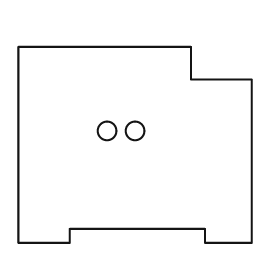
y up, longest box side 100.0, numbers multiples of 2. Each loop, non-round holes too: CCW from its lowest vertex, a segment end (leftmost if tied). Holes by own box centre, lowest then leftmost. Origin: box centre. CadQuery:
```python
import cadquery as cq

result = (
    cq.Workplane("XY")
    .moveTo(-50.0, -42.0)
    .lineTo(-28.0, -42.0)
    .lineTo(-28.0, -36.0)
    .lineTo(30.0, -36.0)
    .lineTo(30.0, -42.0)
    .lineTo(50.0, -42.0)
    .lineTo(50.0, 28.0)
    .lineTo(24.0, 28.0)
    .lineTo(24.0, 42.0)
    .lineTo(-50.0, 42.0)
    .close()
    .moveTo(-12.0, 6.0)
    .circle(4.0)
    .moveTo(0.0, 6.0)
    .circle(4.0)
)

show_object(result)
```